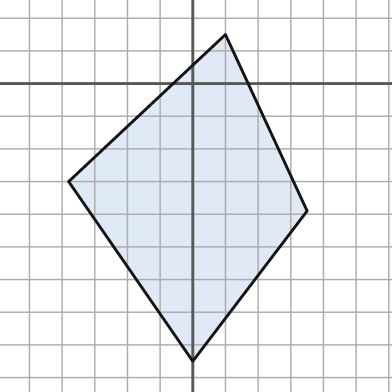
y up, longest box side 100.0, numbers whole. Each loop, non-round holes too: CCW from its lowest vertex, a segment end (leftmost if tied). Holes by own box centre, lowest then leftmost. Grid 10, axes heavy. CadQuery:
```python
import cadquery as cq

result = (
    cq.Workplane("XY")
    .moveTo(0.0, -85.0)
    .lineTo(35.0, -39.0)
    .lineTo(10.0, 15.0)
    .lineTo(-38.0, -30.0)
    .close()
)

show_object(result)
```